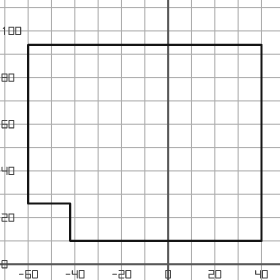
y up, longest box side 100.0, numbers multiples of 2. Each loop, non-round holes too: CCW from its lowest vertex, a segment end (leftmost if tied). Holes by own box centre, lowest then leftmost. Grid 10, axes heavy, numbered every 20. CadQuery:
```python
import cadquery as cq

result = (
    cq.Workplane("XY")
    .moveTo(-42.0, 10.0)
    .lineTo(40.0, 10.0)
    .lineTo(40.0, 94.0)
    .lineTo(-60.0, 94.0)
    .lineTo(-60.0, 26.0)
    .lineTo(-42.0, 26.0)
    .close()
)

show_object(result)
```